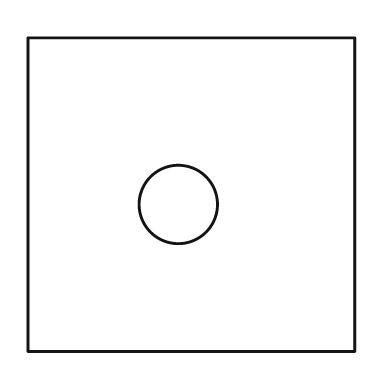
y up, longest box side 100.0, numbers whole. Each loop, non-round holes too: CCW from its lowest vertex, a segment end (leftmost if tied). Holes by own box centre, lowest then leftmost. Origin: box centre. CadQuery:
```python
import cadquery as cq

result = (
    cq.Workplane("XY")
    .moveTo(-50.0, -48.0)
    .lineTo(50.0, -48.0)
    .lineTo(50.0, 48.0)
    .lineTo(-50.0, 48.0)
    .close()
    .moveTo(-4.0, -3.0)
    .circle(12.0)
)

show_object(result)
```